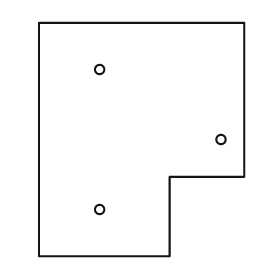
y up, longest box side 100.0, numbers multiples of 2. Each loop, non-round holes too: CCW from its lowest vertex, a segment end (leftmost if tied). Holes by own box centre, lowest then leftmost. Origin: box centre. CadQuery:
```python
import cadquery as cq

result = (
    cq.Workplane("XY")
    .moveTo(-44.0, -50.0)
    .lineTo(12.0, -50.0)
    .lineTo(12.0, -16.0)
    .lineTo(44.0, -16.0)
    .lineTo(44.0, 50.0)
    .lineTo(-44.0, 50.0)
    .close()
    .moveTo(-18.0, -30.0)
    .circle(2.0)
    .moveTo(34.0, 0.0)
    .circle(2.0)
    .moveTo(-18.0, 30.0)
    .circle(2.0)
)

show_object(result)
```